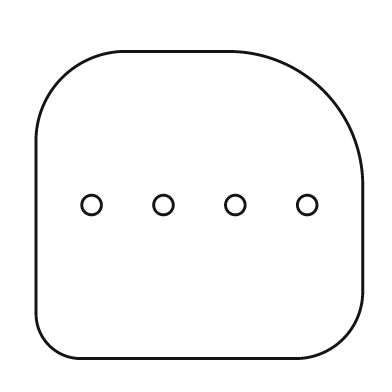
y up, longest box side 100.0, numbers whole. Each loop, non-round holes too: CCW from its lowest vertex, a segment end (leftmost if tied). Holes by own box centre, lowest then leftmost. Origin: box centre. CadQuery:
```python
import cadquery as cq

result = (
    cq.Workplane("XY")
    .moveTo(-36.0, -47.0)
    .lineTo(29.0, -47.0)
    .threePointArc((44.0, -41.0), (50.0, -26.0))
    .lineTo(50.0, 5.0)
    .threePointArc((38.0, 35.0), (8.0, 47.0))
    .lineTo(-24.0, 47.0)
    .threePointArc((-42.0, 39.0), (-50.0, 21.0))
    .lineTo(-50.0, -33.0)
    .threePointArc((-46.0, -43.0), (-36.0, -47.0))
    .close()
    .moveTo(-33.0, 0.0)
    .circle(3.0)
    .moveTo(-11.0, 0.0)
    .circle(3.0)
    .moveTo(11.0, 0.0)
    .circle(3.0)
    .moveTo(33.0, 0.0)
    .circle(3.0)
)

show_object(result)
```